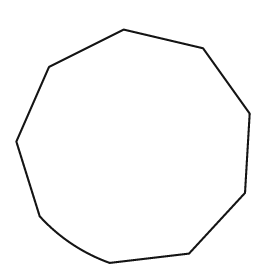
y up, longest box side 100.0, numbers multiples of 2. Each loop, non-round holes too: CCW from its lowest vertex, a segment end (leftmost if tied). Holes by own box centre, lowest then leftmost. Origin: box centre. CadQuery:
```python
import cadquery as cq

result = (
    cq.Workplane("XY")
    .moveTo(-10.0, -50.0)
    .lineTo(24.0, -46.0)
    .lineTo(48.0, -20.0)
    .lineTo(50.0, 14.0)
    .lineTo(30.0, 42.0)
    .lineTo(-4.0, 50.0)
    .lineTo(-36.0, 34.0)
    .lineTo(-50.0, 2.0)
    .lineTo(-40.0, -30.0)
    .threePointArc((-26.0, -42.0), (-10.0, -50.0))
    .close()
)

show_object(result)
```